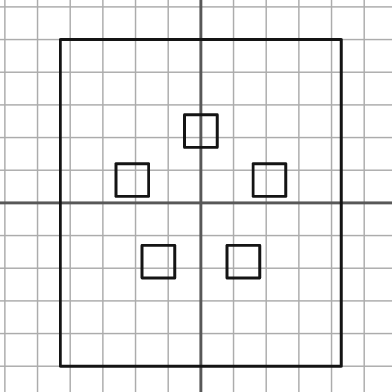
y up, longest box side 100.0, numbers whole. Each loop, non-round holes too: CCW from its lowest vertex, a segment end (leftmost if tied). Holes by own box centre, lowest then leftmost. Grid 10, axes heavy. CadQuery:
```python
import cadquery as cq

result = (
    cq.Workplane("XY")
    .moveTo(-43.0, -50.0)
    .lineTo(43.0, -50.0)
    .lineTo(43.0, 50.0)
    .lineTo(-43.0, 50.0)
    .close()
    .moveTo(-18.0, -23.0)
    .lineTo(-8.0, -23.0)
    .lineTo(-8.0, -13.0)
    .lineTo(-18.0, -13.0)
    .close()
    .moveTo(8.0, -23.0)
    .lineTo(18.0, -23.0)
    .lineTo(18.0, -13.0)
    .lineTo(8.0, -13.0)
    .close()
    .moveTo(-26.0, 2.0)
    .lineTo(-16.0, 2.0)
    .lineTo(-16.0, 12.0)
    .lineTo(-26.0, 12.0)
    .close()
    .moveTo(16.0, 2.0)
    .lineTo(26.0, 2.0)
    .lineTo(26.0, 12.0)
    .lineTo(16.0, 12.0)
    .close()
    .moveTo(-5.0, 17.0)
    .lineTo(5.0, 17.0)
    .lineTo(5.0, 27.0)
    .lineTo(-5.0, 27.0)
    .close()
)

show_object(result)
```